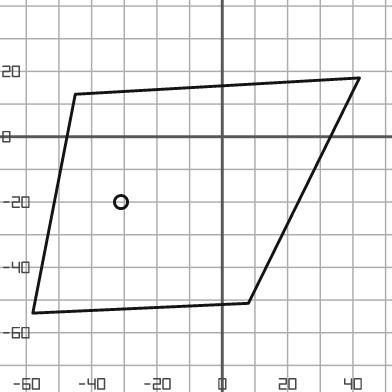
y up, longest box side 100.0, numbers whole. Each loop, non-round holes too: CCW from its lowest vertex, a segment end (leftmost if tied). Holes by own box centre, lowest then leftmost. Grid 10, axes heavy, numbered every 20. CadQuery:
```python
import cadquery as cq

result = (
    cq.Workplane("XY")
    .moveTo(-58.0, -54.0)
    .lineTo(8.0, -51.0)
    .lineTo(42.0, 18.0)
    .lineTo(-45.0, 13.0)
    .close()
    .moveTo(-31.0, -20.0)
    .circle(2.0)
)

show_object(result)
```